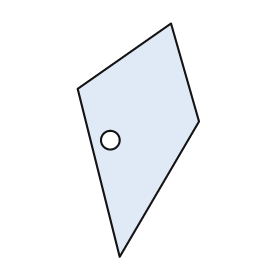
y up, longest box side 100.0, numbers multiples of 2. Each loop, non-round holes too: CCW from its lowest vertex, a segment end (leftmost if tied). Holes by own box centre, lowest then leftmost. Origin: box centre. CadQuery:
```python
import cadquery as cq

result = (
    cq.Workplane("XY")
    .moveTo(-8.0, -50.0)
    .lineTo(26.0, 8.0)
    .lineTo(14.0, 50.0)
    .lineTo(-26.0, 22.0)
    .close()
    .moveTo(-12.0, 0.0)
    .circle(4.0)
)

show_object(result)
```